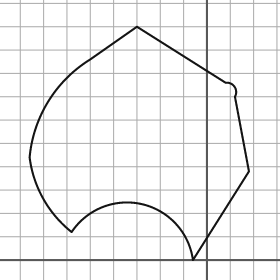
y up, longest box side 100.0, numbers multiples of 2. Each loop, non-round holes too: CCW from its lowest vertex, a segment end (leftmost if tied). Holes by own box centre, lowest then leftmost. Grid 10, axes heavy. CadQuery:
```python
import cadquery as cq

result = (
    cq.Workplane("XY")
    .moveTo(-6.0, 0.0)
    .lineTo(18.0, 38.0)
    .lineTo(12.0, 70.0)
    .threePointArc((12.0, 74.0), (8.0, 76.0))
    .lineTo(-30.0, 100.0)
    .lineTo(-50.0, 86.0)
    .threePointArc((-68.0, 68.0), (-76.0, 44.0))
    .threePointArc((-70.0, 26.0), (-58.0, 12.0))
    .threePointArc((-28.0, 24.0), (-6.0, 0.0))
    .close()
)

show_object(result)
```